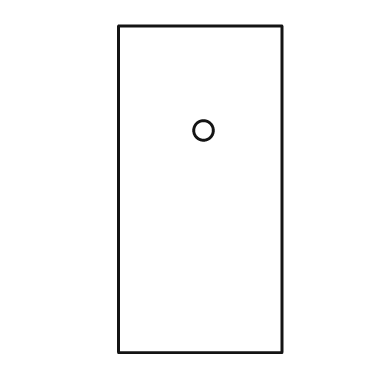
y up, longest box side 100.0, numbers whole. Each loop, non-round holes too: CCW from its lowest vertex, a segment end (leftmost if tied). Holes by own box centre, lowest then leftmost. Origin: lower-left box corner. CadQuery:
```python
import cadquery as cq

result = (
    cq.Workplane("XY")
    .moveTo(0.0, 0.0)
    .lineTo(50.0, 0.0)
    .lineTo(50.0, 100.0)
    .lineTo(0.0, 100.0)
    .close()
    .moveTo(26.0, 68.0)
    .circle(3.0)
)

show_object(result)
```